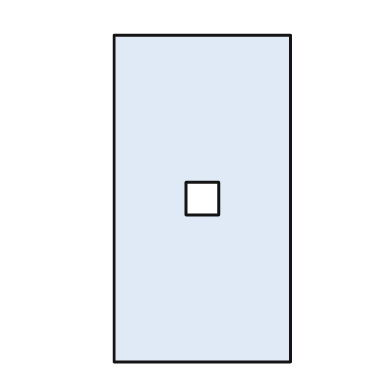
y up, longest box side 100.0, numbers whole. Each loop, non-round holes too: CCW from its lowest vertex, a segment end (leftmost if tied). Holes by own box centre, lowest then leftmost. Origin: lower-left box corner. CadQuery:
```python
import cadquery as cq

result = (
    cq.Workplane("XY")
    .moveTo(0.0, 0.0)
    .lineTo(54.0, 0.0)
    .lineTo(54.0, 100.0)
    .lineTo(0.0, 100.0)
    .close()
    .moveTo(22.0, 45.0)
    .lineTo(32.0, 45.0)
    .lineTo(32.0, 55.0)
    .lineTo(22.0, 55.0)
    .close()
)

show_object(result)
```